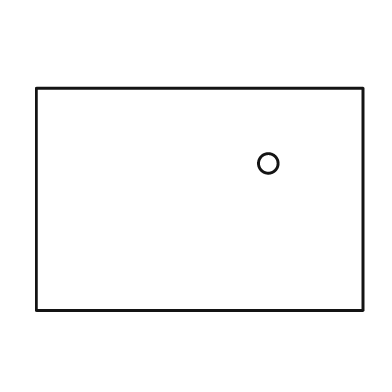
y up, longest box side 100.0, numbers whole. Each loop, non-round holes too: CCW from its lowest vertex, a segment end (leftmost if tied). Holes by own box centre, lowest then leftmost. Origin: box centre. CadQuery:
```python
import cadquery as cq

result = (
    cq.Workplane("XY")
    .moveTo(-50.0, -34.0)
    .lineTo(50.0, -34.0)
    .lineTo(50.0, 34.0)
    .lineTo(-50.0, 34.0)
    .close()
    .moveTo(21.0, 11.0)
    .circle(3.0)
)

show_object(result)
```